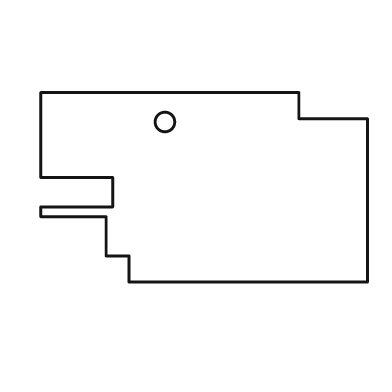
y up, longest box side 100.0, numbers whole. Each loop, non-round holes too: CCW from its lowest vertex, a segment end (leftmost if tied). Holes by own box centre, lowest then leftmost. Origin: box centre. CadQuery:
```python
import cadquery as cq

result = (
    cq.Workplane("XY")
    .moveTo(-23.0, -29.0)
    .lineTo(50.0, -29.0)
    .lineTo(50.0, 21.0)
    .lineTo(29.0, 21.0)
    .lineTo(29.0, 29.0)
    .lineTo(-50.0, 29.0)
    .lineTo(-50.0, 3.0)
    .lineTo(-28.0, 3.0)
    .lineTo(-28.0, -6.0)
    .lineTo(-50.0, -6.0)
    .lineTo(-50.0, -9.0)
    .lineTo(-30.0, -9.0)
    .lineTo(-30.0, -21.0)
    .lineTo(-23.0, -21.0)
    .close()
    .moveTo(-12.0, 20.0)
    .circle(3.0)
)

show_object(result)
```